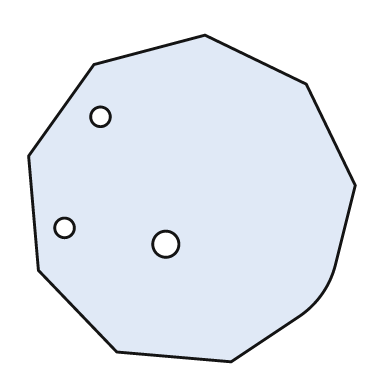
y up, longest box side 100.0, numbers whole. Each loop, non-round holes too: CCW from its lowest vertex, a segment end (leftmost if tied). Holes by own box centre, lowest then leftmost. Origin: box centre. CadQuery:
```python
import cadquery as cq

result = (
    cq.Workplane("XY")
    .moveTo(12.0, -50.0)
    .lineTo(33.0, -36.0)
    .threePointArc((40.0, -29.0), (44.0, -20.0))
    .lineTo(50.0, 4.0)
    .lineTo(35.0, 35.0)
    .lineTo(4.0, 50.0)
    .lineTo(-30.0, 41.0)
    .lineTo(-50.0, 13.0)
    .lineTo(-47.0, -22.0)
    .lineTo(-23.0, -47.0)
    .close()
    .moveTo(-8.0, -14.0)
    .circle(4.0)
    .moveTo(-39.0, -9.0)
    .circle(3.0)
    .moveTo(-28.0, 25.0)
    .circle(3.0)
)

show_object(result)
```